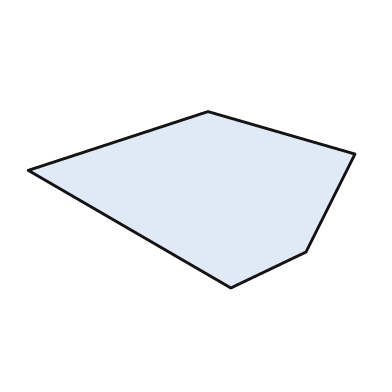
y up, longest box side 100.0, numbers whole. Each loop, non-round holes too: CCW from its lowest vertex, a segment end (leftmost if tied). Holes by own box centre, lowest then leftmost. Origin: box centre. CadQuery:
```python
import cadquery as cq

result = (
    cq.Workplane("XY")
    .moveTo(12.0, -27.0)
    .lineTo(35.0, -16.0)
    .lineTo(50.0, 14.0)
    .lineTo(5.0, 27.0)
    .lineTo(-50.0, 9.0)
    .close()
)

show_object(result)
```